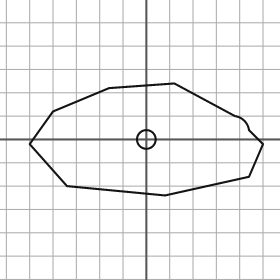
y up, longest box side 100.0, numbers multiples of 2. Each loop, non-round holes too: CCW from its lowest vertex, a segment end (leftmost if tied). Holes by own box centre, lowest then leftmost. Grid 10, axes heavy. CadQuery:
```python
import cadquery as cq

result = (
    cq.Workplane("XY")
    .moveTo(8.0, -24.0)
    .lineTo(44.0, -16.0)
    .lineTo(50.0, -2.0)
    .lineTo(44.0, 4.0)
    .threePointArc((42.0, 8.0), (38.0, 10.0))
    .lineTo(12.0, 24.0)
    .lineTo(-16.0, 22.0)
    .lineTo(-40.0, 12.0)
    .lineTo(-50.0, -2.0)
    .lineTo(-34.0, -20.0)
    .close()
    .moveTo(0.0, 0.0)
    .circle(4.0)
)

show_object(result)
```